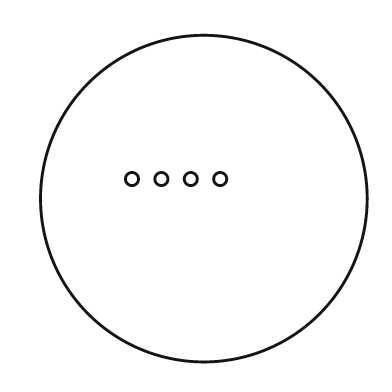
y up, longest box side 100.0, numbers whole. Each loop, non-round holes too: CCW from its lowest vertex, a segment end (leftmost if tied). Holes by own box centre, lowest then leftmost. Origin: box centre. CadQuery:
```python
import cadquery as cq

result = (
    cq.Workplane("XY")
    .moveTo(0.0, 0.0)
    .circle(50.0)
    .moveTo(-22.0, 6.0)
    .circle(2.0)
    .moveTo(-13.0, 6.0)
    .circle(2.0)
    .moveTo(-4.0, 6.0)
    .circle(2.0)
    .moveTo(5.0, 6.0)
    .circle(2.0)
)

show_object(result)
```